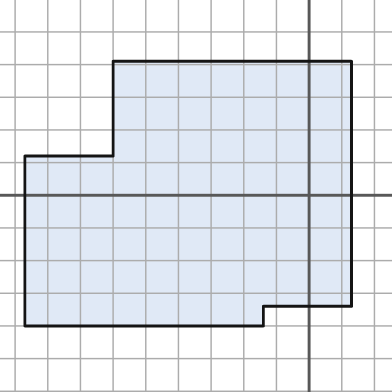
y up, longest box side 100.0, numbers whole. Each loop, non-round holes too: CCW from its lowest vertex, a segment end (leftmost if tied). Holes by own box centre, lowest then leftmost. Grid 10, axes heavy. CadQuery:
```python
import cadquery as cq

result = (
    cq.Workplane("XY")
    .moveTo(-87.0, -40.0)
    .lineTo(-14.0, -40.0)
    .lineTo(-14.0, -34.0)
    .lineTo(13.0, -34.0)
    .lineTo(13.0, 41.0)
    .lineTo(-60.0, 41.0)
    .lineTo(-60.0, 12.0)
    .lineTo(-87.0, 12.0)
    .close()
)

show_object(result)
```